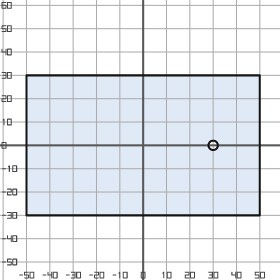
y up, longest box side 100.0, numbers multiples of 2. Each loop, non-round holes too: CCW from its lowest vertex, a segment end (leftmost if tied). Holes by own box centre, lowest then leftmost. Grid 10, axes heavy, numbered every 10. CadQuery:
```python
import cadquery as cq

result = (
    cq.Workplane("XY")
    .moveTo(-50.0, -30.0)
    .lineTo(50.0, -30.0)
    .lineTo(50.0, 30.0)
    .lineTo(-50.0, 30.0)
    .close()
    .moveTo(30.0, 0.0)
    .circle(2.0)
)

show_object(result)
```